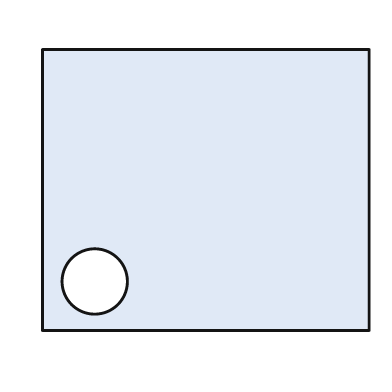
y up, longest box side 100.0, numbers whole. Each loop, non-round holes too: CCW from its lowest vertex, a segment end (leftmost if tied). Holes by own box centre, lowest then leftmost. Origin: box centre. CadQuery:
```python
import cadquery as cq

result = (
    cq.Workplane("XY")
    .moveTo(-50.0, -43.0)
    .lineTo(50.0, -43.0)
    .lineTo(50.0, 43.0)
    .lineTo(-50.0, 43.0)
    .close()
    .moveTo(-34.0, -28.0)
    .circle(10.0)
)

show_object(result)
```